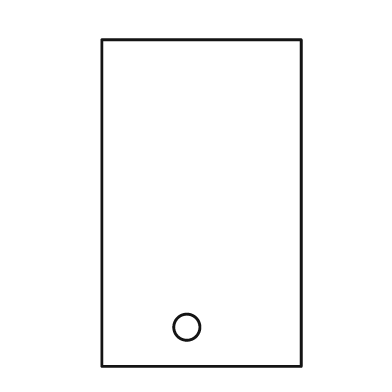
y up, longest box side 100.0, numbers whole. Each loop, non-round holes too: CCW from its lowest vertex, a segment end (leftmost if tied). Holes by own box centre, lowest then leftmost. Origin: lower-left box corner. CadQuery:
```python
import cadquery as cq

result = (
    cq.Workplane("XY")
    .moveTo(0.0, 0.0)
    .lineTo(61.0, 0.0)
    .lineTo(61.0, 100.0)
    .lineTo(0.0, 100.0)
    .close()
    .moveTo(26.0, 12.0)
    .circle(4.0)
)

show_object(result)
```